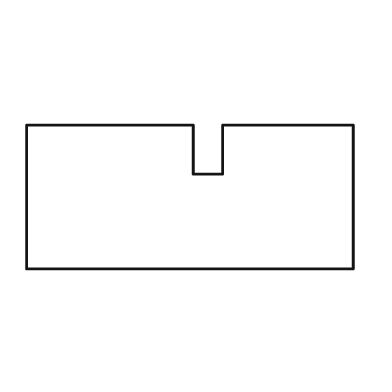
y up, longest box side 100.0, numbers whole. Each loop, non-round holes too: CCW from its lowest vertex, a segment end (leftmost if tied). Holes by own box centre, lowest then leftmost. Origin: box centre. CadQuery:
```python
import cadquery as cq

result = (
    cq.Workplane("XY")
    .moveTo(-50.0, -22.0)
    .lineTo(50.0, -22.0)
    .lineTo(50.0, 22.0)
    .lineTo(10.0, 22.0)
    .lineTo(10.0, 7.0)
    .lineTo(1.0, 7.0)
    .lineTo(1.0, 22.0)
    .lineTo(-50.0, 22.0)
    .close()
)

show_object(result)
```